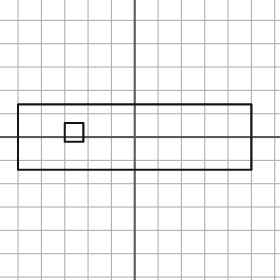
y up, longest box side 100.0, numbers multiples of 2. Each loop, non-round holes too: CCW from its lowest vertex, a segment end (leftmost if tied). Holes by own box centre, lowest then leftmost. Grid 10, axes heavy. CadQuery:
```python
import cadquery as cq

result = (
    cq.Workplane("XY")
    .moveTo(-50.0, -14.0)
    .lineTo(50.0, -14.0)
    .lineTo(50.0, 14.0)
    .lineTo(-50.0, 14.0)
    .close()
    .moveTo(-30.0, -2.0)
    .lineTo(-22.0, -2.0)
    .lineTo(-22.0, 6.0)
    .lineTo(-30.0, 6.0)
    .close()
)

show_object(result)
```